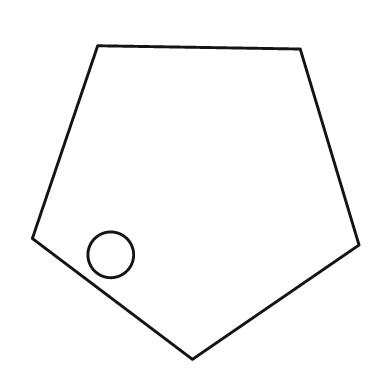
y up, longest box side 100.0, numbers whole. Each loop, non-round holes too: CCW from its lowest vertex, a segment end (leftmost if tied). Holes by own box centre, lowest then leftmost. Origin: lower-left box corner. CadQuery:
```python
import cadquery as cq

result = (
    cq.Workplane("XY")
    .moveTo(49.0, 0.0)
    .lineTo(100.0, 35.0)
    .lineTo(82.0, 95.0)
    .lineTo(20.0, 96.0)
    .lineTo(0.0, 37.0)
    .close()
    .moveTo(24.0, 32.0)
    .circle(7.0)
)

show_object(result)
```